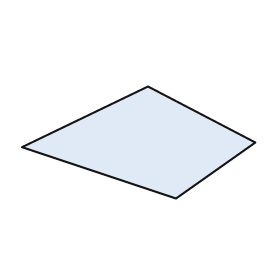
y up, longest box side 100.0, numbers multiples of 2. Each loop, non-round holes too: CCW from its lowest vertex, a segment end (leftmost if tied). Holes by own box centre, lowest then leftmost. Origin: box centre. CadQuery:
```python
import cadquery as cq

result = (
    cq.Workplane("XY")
    .moveTo(16.0, -24.0)
    .lineTo(50.0, 0.0)
    .lineTo(4.0, 24.0)
    .lineTo(-50.0, -2.0)
    .close()
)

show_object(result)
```